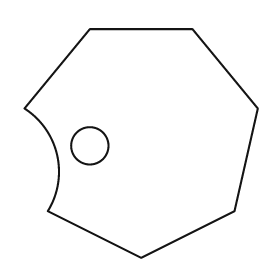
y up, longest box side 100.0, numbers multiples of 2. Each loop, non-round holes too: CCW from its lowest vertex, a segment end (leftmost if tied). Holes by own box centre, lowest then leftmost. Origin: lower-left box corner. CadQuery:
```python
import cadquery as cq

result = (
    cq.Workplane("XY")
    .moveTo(50.0, 0.0)
    .lineTo(90.0, 20.0)
    .lineTo(100.0, 64.0)
    .lineTo(72.0, 98.0)
    .lineTo(28.0, 98.0)
    .lineTo(0.0, 64.0)
    .threePointArc((14.0, 44.0), (10.0, 20.0))
    .close()
    .moveTo(28.0, 48.0)
    .circle(8.0)
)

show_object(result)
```